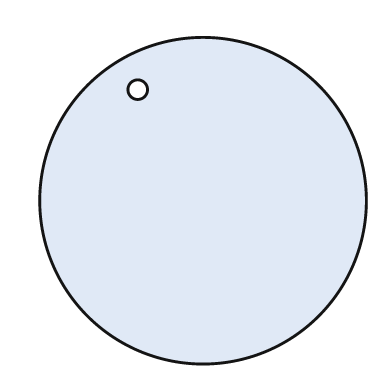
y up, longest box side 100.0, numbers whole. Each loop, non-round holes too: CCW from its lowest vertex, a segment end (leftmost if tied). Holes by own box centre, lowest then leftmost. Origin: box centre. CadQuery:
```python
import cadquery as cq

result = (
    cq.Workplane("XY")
    .moveTo(0.0, 0.0)
    .circle(50.0)
    .moveTo(-20.0, 34.0)
    .circle(3.0)
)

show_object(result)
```